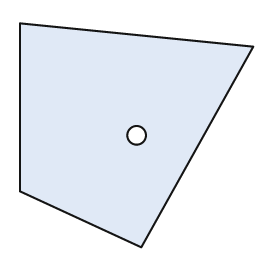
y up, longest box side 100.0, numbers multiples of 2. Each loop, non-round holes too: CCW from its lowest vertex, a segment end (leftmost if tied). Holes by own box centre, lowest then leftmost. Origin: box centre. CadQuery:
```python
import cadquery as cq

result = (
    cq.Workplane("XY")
    .moveTo(2.0, -48.0)
    .lineTo(50.0, 38.0)
    .lineTo(-50.0, 48.0)
    .lineTo(-50.0, -24.0)
    .close()
    .moveTo(0.0, 0.0)
    .circle(4.0)
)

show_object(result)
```